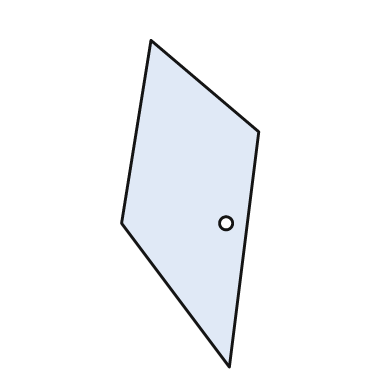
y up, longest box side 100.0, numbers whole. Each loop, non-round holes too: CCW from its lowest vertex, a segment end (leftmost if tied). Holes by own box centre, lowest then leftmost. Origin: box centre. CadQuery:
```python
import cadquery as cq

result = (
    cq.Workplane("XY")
    .moveTo(12.0, -50.0)
    .lineTo(21.0, 22.0)
    .lineTo(-12.0, 50.0)
    .lineTo(-21.0, -6.0)
    .close()
    .moveTo(11.0, -6.0)
    .circle(2.0)
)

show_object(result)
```